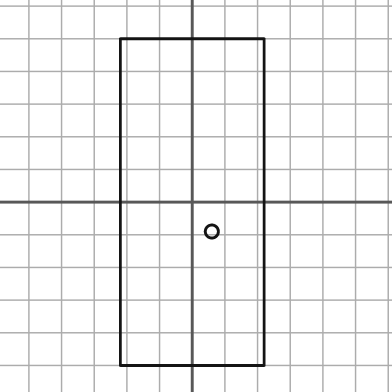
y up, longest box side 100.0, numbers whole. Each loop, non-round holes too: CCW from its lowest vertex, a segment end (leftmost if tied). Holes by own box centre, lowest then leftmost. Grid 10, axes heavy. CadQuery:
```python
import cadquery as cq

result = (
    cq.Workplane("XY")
    .moveTo(-22.0, -50.0)
    .lineTo(22.0, -50.0)
    .lineTo(22.0, 50.0)
    .lineTo(-22.0, 50.0)
    .close()
    .moveTo(6.0, -9.0)
    .circle(2.0)
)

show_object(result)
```